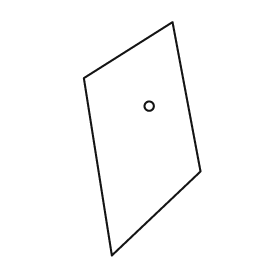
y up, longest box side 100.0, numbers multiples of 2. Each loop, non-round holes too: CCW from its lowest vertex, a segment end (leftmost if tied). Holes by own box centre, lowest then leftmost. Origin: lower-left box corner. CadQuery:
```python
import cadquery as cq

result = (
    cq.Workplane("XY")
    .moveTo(12.0, 0.0)
    .lineTo(50.0, 36.0)
    .lineTo(38.0, 100.0)
    .lineTo(0.0, 76.0)
    .close()
    .moveTo(28.0, 64.0)
    .circle(2.0)
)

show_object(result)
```